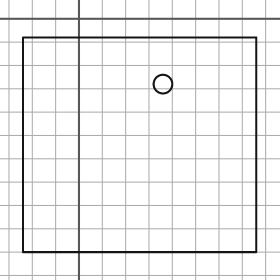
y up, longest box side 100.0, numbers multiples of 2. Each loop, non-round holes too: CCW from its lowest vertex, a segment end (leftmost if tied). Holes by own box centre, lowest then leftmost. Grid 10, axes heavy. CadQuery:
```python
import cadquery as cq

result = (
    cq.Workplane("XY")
    .moveTo(-24.0, -100.0)
    .lineTo(76.0, -100.0)
    .lineTo(76.0, -8.0)
    .lineTo(-24.0, -8.0)
    .close()
    .moveTo(36.0, -28.0)
    .circle(4.0)
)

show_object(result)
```